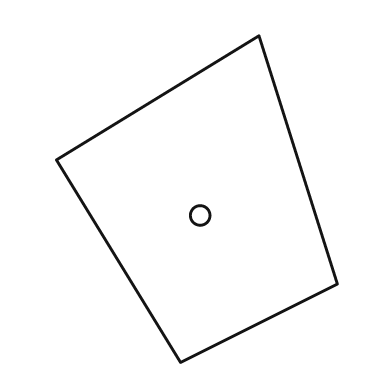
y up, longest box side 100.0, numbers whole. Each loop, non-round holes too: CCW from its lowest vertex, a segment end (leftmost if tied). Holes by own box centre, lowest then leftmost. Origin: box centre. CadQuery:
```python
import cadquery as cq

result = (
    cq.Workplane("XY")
    .moveTo(-5.0, -50.0)
    .lineTo(43.0, -26.0)
    .lineTo(19.0, 50.0)
    .lineTo(-43.0, 12.0)
    .close()
    .moveTo(1.0, -5.0)
    .circle(3.0)
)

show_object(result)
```